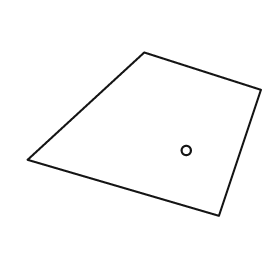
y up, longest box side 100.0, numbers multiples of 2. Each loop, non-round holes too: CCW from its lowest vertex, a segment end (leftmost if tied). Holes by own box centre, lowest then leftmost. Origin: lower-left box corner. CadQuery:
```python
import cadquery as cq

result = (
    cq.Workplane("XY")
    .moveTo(82.0, 0.0)
    .lineTo(100.0, 54.0)
    .lineTo(50.0, 70.0)
    .lineTo(0.0, 24.0)
    .close()
    .moveTo(68.0, 28.0)
    .circle(2.0)
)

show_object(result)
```